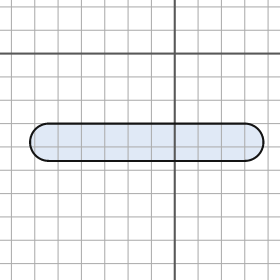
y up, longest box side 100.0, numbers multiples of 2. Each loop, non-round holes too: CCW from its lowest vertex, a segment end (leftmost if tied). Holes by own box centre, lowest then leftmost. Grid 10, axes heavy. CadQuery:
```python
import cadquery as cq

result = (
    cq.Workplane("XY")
    .moveTo(-54.0, -46.0)
    .lineTo(30.0, -46.0)
    .threePointArc((38.0, -38.0), (30.0, -30.0))
    .lineTo(-54.0, -30.0)
    .threePointArc((-62.0, -38.0), (-54.0, -46.0))
    .close()
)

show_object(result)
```